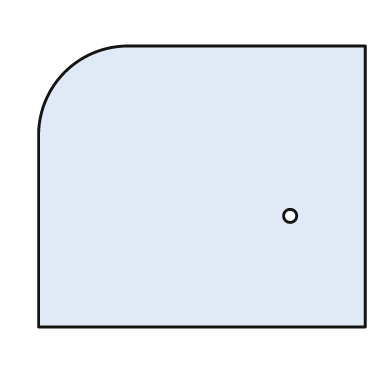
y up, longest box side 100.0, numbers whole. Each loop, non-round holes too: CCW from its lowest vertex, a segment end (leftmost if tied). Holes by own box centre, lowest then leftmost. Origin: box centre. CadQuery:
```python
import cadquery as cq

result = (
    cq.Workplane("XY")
    .moveTo(-50.0, -43.0)
    .lineTo(50.0, -43.0)
    .lineTo(50.0, 43.0)
    .lineTo(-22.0, 43.0)
    .threePointArc((-42.0, 35.0), (-50.0, 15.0))
    .close()
    .moveTo(27.0, -9.0)
    .circle(2.0)
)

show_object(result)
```